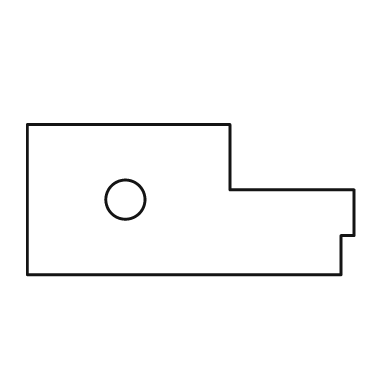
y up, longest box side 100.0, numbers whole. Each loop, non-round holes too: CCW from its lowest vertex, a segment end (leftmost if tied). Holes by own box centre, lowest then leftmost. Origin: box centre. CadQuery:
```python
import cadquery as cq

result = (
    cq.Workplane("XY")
    .moveTo(-50.0, -23.0)
    .lineTo(46.0, -23.0)
    .lineTo(46.0, -11.0)
    .lineTo(50.0, -11.0)
    .lineTo(50.0, 3.0)
    .lineTo(12.0, 3.0)
    .lineTo(12.0, 23.0)
    .lineTo(-50.0, 23.0)
    .close()
    .moveTo(-20.0, 0.0)
    .circle(6.0)
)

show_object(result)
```